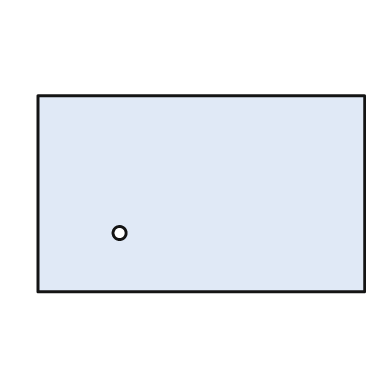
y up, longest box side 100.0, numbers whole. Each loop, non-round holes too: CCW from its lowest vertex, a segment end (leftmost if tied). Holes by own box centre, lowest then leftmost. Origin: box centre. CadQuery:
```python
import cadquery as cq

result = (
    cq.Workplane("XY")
    .moveTo(-50.0, -30.0)
    .lineTo(50.0, -30.0)
    .lineTo(50.0, 30.0)
    .lineTo(-50.0, 30.0)
    .close()
    .moveTo(-25.0, -12.0)
    .circle(2.0)
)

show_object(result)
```